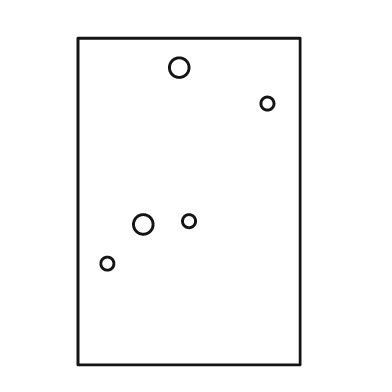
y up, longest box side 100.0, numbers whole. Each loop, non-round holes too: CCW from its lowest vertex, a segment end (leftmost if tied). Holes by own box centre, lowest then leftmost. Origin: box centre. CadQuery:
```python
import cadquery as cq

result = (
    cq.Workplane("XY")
    .moveTo(-34.0, -50.0)
    .lineTo(34.0, -50.0)
    .lineTo(34.0, 50.0)
    .lineTo(-34.0, 50.0)
    .close()
    .moveTo(-25.0, -19.0)
    .circle(2.0)
    .moveTo(-14.0, -7.0)
    .circle(3.0)
    .moveTo(0.0, -6.0)
    .circle(2.0)
    .moveTo(24.0, 30.0)
    .circle(2.0)
    .moveTo(-3.0, 41.0)
    .circle(3.0)
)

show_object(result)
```